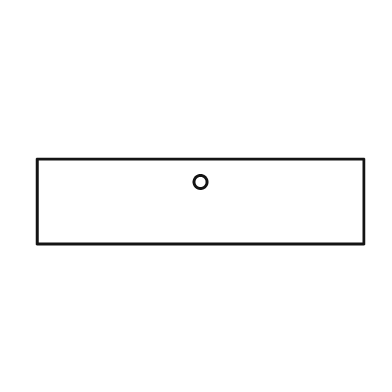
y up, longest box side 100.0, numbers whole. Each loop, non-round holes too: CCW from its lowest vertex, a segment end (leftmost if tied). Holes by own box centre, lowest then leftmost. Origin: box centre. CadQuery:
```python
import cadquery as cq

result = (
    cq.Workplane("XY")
    .moveTo(-50.0, -13.0)
    .lineTo(50.0, -13.0)
    .lineTo(50.0, 13.0)
    .lineTo(-50.0, 13.0)
    .close()
    .moveTo(0.0, 6.0)
    .circle(2.0)
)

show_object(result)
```